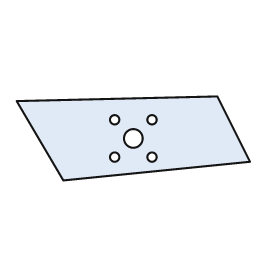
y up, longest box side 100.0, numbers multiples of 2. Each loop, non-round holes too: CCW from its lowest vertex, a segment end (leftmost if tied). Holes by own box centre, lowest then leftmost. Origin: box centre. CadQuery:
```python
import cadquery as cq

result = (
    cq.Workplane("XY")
    .moveTo(-30.0, -18.0)
    .lineTo(50.0, -10.0)
    .lineTo(36.0, 18.0)
    .lineTo(-50.0, 16.0)
    .close()
    .moveTo(-8.0, -8.0)
    .circle(2.0)
    .moveTo(8.0, -8.0)
    .circle(2.0)
    .moveTo(0.0, 0.0)
    .circle(4.0)
    .moveTo(-8.0, 8.0)
    .circle(2.0)
    .moveTo(8.0, 8.0)
    .circle(2.0)
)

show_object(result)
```